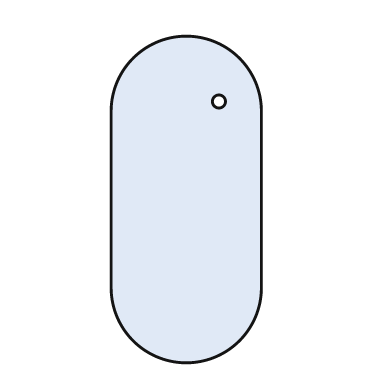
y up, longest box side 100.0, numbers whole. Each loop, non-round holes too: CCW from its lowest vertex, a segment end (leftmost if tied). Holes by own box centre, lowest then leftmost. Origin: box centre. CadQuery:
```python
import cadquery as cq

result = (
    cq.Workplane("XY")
    .moveTo(-23.0, -27.0)
    .threePointArc((0.0, -50.0), (23.0, -27.0))
    .lineTo(23.0, 27.0)
    .threePointArc((0.0, 50.0), (-23.0, 27.0))
    .close()
    .moveTo(10.0, 30.0)
    .circle(2.0)
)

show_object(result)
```